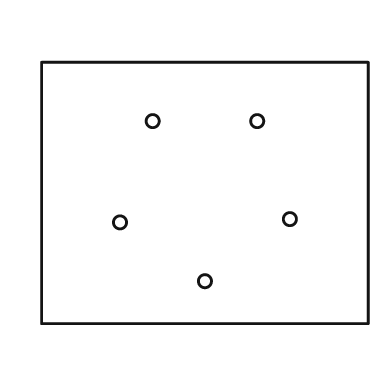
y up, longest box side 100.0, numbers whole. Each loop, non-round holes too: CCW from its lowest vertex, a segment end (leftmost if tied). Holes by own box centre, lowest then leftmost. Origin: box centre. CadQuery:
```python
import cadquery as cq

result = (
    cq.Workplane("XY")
    .moveTo(-50.0, -40.0)
    .lineTo(50.0, -40.0)
    .lineTo(50.0, 40.0)
    .lineTo(-50.0, 40.0)
    .close()
    .moveTo(0.0, -27.0)
    .circle(2.0)
    .moveTo(-26.0, -9.0)
    .circle(2.0)
    .moveTo(26.0, -8.0)
    .circle(2.0)
    .moveTo(-16.0, 22.0)
    .circle(2.0)
    .moveTo(16.0, 22.0)
    .circle(2.0)
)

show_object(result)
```